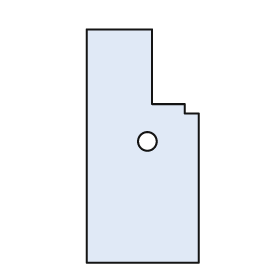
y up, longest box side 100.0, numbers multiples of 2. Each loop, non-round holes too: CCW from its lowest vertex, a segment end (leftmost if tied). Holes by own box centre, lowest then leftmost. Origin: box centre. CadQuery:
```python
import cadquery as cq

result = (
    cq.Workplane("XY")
    .moveTo(-24.0, -50.0)
    .lineTo(24.0, -50.0)
    .lineTo(24.0, 14.0)
    .lineTo(18.0, 14.0)
    .lineTo(18.0, 18.0)
    .lineTo(4.0, 18.0)
    .lineTo(4.0, 50.0)
    .lineTo(-24.0, 50.0)
    .close()
    .moveTo(2.0, 2.0)
    .circle(4.0)
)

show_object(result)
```